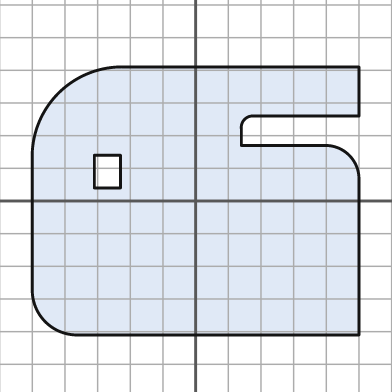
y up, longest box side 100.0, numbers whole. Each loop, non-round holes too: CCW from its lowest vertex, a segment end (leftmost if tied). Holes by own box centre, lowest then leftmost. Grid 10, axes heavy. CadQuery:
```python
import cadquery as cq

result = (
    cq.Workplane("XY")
    .moveTo(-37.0, -41.0)
    .lineTo(50.0, -41.0)
    .lineTo(50.0, 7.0)
    .threePointArc((47.0, 14.0), (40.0, 17.0))
    .lineTo(14.0, 17.0)
    .lineTo(14.0, 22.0)
    .threePointArc((15.0, 25.0), (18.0, 26.0))
    .lineTo(50.0, 26.0)
    .lineTo(50.0, 41.0)
    .lineTo(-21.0, 41.0)
    .threePointArc((-42.0, 33.0), (-50.0, 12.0))
    .lineTo(-50.0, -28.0)
    .threePointArc((-46.0, -37.0), (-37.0, -41.0))
    .close()
    .moveTo(-31.0, 4.0)
    .lineTo(-23.0, 4.0)
    .lineTo(-23.0, 14.0)
    .lineTo(-31.0, 14.0)
    .close()
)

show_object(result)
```